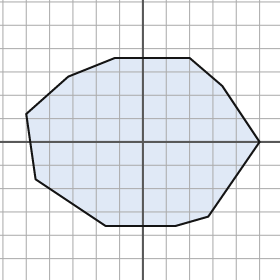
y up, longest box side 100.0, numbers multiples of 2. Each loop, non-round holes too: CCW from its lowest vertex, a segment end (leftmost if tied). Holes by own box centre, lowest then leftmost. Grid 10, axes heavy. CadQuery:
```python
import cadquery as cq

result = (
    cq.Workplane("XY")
    .moveTo(-16.0, -36.0)
    .lineTo(14.0, -36.0)
    .lineTo(28.0, -32.0)
    .lineTo(50.0, 0.0)
    .lineTo(34.0, 24.0)
    .lineTo(20.0, 36.0)
    .lineTo(-12.0, 36.0)
    .lineTo(-32.0, 28.0)
    .lineTo(-50.0, 12.0)
    .lineTo(-46.0, -16.0)
    .close()
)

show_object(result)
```